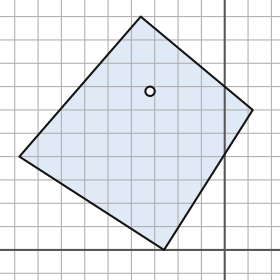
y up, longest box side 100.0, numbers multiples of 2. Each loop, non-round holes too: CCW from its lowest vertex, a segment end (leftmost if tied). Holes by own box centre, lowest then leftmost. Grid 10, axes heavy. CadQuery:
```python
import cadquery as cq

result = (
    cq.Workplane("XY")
    .moveTo(-26.0, 0.0)
    .lineTo(12.0, 60.0)
    .lineTo(-36.0, 100.0)
    .lineTo(-88.0, 40.0)
    .close()
    .moveTo(-32.0, 68.0)
    .circle(2.0)
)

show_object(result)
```